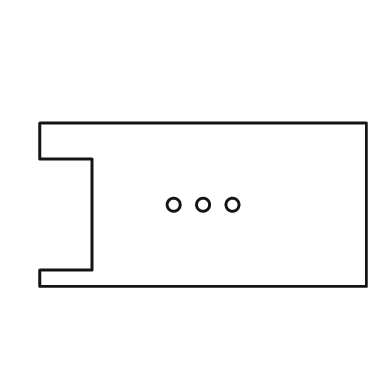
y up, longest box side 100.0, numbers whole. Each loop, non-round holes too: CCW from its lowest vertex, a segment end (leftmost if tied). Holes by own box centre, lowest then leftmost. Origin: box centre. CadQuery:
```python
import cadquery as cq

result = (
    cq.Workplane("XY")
    .moveTo(-50.0, -25.0)
    .lineTo(50.0, -25.0)
    .lineTo(50.0, 25.0)
    .lineTo(-50.0, 25.0)
    .lineTo(-50.0, 14.0)
    .lineTo(-34.0, 14.0)
    .lineTo(-34.0, -20.0)
    .lineTo(-50.0, -20.0)
    .close()
    .moveTo(-9.0, 0.0)
    .circle(2.0)
    .moveTo(0.0, 0.0)
    .circle(2.0)
    .moveTo(9.0, 0.0)
    .circle(2.0)
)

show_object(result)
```